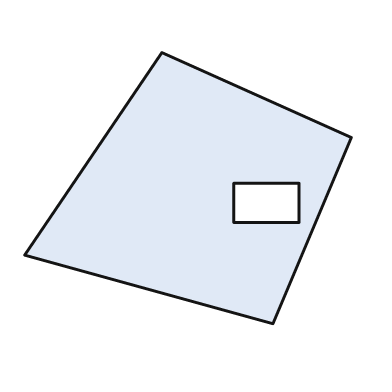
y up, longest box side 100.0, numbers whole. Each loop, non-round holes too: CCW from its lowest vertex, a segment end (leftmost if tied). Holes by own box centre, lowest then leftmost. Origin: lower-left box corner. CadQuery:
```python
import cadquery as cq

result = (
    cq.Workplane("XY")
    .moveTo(76.0, 0.0)
    .lineTo(100.0, 57.0)
    .lineTo(42.0, 83.0)
    .lineTo(0.0, 21.0)
    .close()
    .moveTo(64.0, 31.0)
    .lineTo(84.0, 31.0)
    .lineTo(84.0, 43.0)
    .lineTo(64.0, 43.0)
    .close()
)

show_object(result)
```